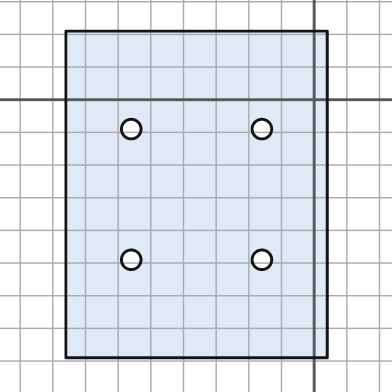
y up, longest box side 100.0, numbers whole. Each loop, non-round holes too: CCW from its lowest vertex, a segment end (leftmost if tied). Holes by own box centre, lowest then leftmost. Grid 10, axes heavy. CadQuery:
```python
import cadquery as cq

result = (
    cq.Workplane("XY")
    .moveTo(-76.0, -79.0)
    .lineTo(4.0, -79.0)
    .lineTo(4.0, 21.0)
    .lineTo(-76.0, 21.0)
    .close()
    .moveTo(-56.0, -49.0)
    .circle(3.0)
    .moveTo(-16.0, -49.0)
    .circle(3.0)
    .moveTo(-56.0, -9.0)
    .circle(3.0)
    .moveTo(-16.0, -9.0)
    .circle(3.0)
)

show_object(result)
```